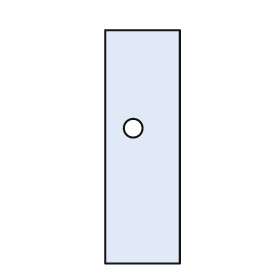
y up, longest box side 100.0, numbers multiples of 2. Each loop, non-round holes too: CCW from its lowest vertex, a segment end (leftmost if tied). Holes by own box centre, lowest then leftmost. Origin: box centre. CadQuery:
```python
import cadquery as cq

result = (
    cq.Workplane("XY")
    .moveTo(-16.0, -50.0)
    .lineTo(16.0, -50.0)
    .lineTo(16.0, 50.0)
    .lineTo(-16.0, 50.0)
    .close()
    .moveTo(-4.0, 8.0)
    .circle(4.0)
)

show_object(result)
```